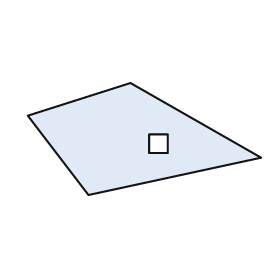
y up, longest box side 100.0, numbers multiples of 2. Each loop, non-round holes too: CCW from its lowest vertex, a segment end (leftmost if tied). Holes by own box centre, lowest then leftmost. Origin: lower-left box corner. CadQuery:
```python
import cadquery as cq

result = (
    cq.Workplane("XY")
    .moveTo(26.0, 0.0)
    .lineTo(100.0, 16.0)
    .lineTo(44.0, 48.0)
    .lineTo(0.0, 34.0)
    .close()
    .moveTo(52.0, 18.0)
    .lineTo(60.0, 18.0)
    .lineTo(60.0, 26.0)
    .lineTo(52.0, 26.0)
    .close()
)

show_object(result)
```